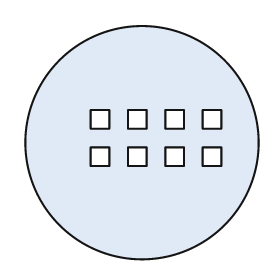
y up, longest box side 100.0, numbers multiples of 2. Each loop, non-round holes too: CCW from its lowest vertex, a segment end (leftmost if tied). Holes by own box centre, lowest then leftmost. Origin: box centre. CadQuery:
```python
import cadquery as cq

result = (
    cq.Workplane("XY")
    .moveTo(0.0, 0.0)
    .circle(50.0)
    .moveTo(-22.0, -10.0)
    .lineTo(-14.0, -10.0)
    .lineTo(-14.0, -2.0)
    .lineTo(-22.0, -2.0)
    .close()
    .moveTo(-6.0, -10.0)
    .lineTo(2.0, -10.0)
    .lineTo(2.0, -2.0)
    .lineTo(-6.0, -2.0)
    .close()
    .moveTo(10.0, -10.0)
    .lineTo(18.0, -10.0)
    .lineTo(18.0, -2.0)
    .lineTo(10.0, -2.0)
    .close()
    .moveTo(26.0, -10.0)
    .lineTo(34.0, -10.0)
    .lineTo(34.0, -2.0)
    .lineTo(26.0, -2.0)
    .close()
    .moveTo(-22.0, 6.0)
    .lineTo(-14.0, 6.0)
    .lineTo(-14.0, 14.0)
    .lineTo(-22.0, 14.0)
    .close()
    .moveTo(-6.0, 6.0)
    .lineTo(2.0, 6.0)
    .lineTo(2.0, 14.0)
    .lineTo(-6.0, 14.0)
    .close()
    .moveTo(10.0, 6.0)
    .lineTo(18.0, 6.0)
    .lineTo(18.0, 14.0)
    .lineTo(10.0, 14.0)
    .close()
    .moveTo(26.0, 6.0)
    .lineTo(34.0, 6.0)
    .lineTo(34.0, 14.0)
    .lineTo(26.0, 14.0)
    .close()
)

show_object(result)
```